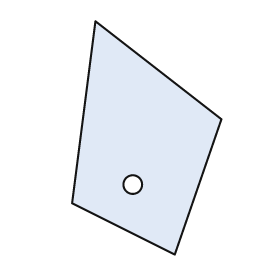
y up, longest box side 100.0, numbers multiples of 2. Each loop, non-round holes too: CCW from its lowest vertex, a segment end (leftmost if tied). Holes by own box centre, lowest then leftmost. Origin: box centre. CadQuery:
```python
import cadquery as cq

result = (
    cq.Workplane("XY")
    .moveTo(12.0, -50.0)
    .lineTo(32.0, 8.0)
    .lineTo(-22.0, 50.0)
    .lineTo(-32.0, -28.0)
    .close()
    .moveTo(-6.0, -20.0)
    .circle(4.0)
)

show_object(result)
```